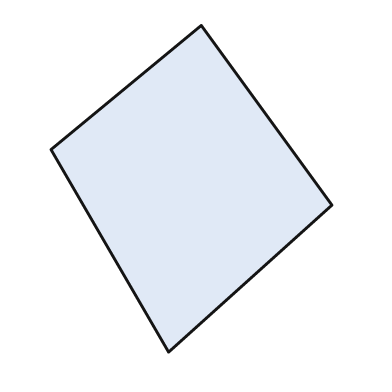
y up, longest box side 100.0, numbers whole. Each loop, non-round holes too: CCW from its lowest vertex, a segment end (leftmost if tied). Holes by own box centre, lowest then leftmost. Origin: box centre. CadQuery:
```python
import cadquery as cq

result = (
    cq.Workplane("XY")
    .moveTo(-7.0, -50.0)
    .lineTo(43.0, -5.0)
    .lineTo(3.0, 50.0)
    .lineTo(-43.0, 12.0)
    .close()
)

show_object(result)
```